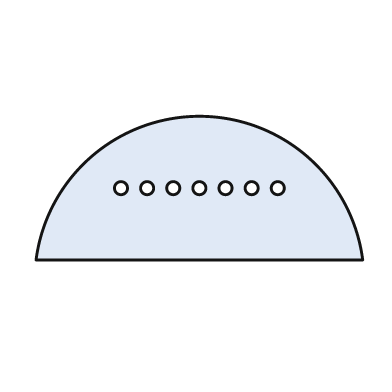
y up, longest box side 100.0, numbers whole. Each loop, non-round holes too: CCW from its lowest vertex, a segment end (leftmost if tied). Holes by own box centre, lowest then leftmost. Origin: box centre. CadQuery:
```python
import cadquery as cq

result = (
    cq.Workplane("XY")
    .moveTo(-50.0, -22.0)
    .lineTo(50.0, -22.0)
    .threePointArc((0.0, 22.0), (-50.0, -22.0))
    .close()
    .moveTo(-24.0, 0.0)
    .circle(2.0)
    .moveTo(-16.0, 0.0)
    .circle(2.0)
    .moveTo(-8.0, 0.0)
    .circle(2.0)
    .moveTo(0.0, 0.0)
    .circle(2.0)
    .moveTo(8.0, 0.0)
    .circle(2.0)
    .moveTo(16.0, 0.0)
    .circle(2.0)
    .moveTo(24.0, 0.0)
    .circle(2.0)
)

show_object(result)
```